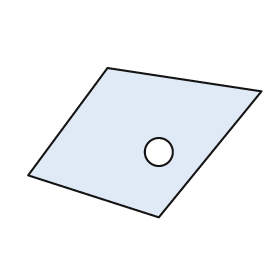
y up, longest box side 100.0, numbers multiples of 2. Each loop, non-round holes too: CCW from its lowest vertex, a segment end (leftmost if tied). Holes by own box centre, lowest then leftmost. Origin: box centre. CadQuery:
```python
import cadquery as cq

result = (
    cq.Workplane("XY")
    .moveTo(6.0, -32.0)
    .lineTo(50.0, 22.0)
    .lineTo(-16.0, 32.0)
    .lineTo(-50.0, -14.0)
    .close()
    .moveTo(6.0, -4.0)
    .circle(6.0)
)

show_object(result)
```